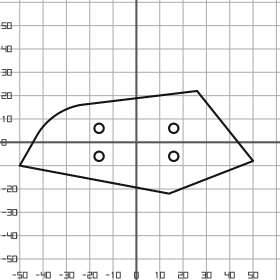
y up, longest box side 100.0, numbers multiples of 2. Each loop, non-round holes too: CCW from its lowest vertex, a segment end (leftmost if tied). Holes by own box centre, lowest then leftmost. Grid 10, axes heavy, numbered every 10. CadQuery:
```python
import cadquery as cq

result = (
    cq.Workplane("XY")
    .moveTo(14.0, -22.0)
    .lineTo(50.0, -8.0)
    .lineTo(26.0, 22.0)
    .lineTo(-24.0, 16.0)
    .threePointArc((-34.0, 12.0), (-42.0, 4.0))
    .lineTo(-50.0, -10.0)
    .close()
    .moveTo(-16.0, -6.0)
    .circle(2.0)
    .moveTo(16.0, -6.0)
    .circle(2.0)
    .moveTo(-16.0, 6.0)
    .circle(2.0)
    .moveTo(16.0, 6.0)
    .circle(2.0)
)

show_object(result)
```